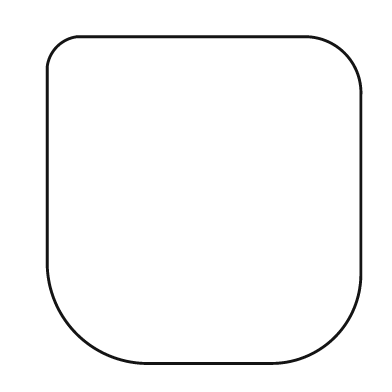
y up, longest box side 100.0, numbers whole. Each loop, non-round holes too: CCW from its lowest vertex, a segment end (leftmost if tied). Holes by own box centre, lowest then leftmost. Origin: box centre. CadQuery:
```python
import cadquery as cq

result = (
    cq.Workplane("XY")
    .moveTo(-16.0, -50.0)
    .lineTo(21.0, -50.0)
    .threePointArc((40.0, -42.0), (48.0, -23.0))
    .lineTo(48.0, 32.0)
    .threePointArc((43.0, 45.0), (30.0, 50.0))
    .lineTo(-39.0, 50.0)
    .threePointArc((-45.0, 47.0), (-48.0, 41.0))
    .lineTo(-48.0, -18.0)
    .threePointArc((-39.0, -41.0), (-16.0, -50.0))
    .close()
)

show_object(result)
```